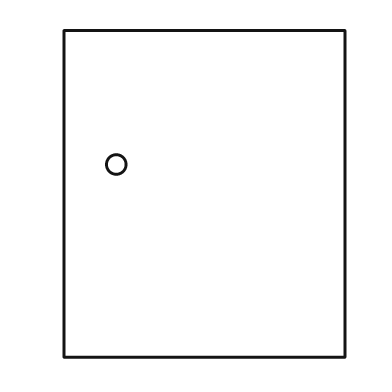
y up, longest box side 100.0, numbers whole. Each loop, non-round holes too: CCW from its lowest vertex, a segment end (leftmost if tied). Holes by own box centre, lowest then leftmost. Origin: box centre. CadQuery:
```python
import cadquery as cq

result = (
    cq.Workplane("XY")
    .moveTo(-43.0, -50.0)
    .lineTo(43.0, -50.0)
    .lineTo(43.0, 50.0)
    .lineTo(-43.0, 50.0)
    .close()
    .moveTo(-27.0, 9.0)
    .circle(3.0)
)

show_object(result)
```